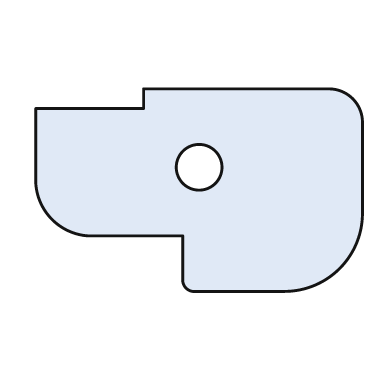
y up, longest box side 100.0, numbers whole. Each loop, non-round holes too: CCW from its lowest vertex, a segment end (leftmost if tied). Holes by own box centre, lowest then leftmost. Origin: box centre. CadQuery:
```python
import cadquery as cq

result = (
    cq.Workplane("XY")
    .moveTo(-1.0, -31.0)
    .lineTo(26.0, -31.0)
    .threePointArc((43.0, -24.0), (50.0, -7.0))
    .lineTo(50.0, 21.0)
    .threePointArc((47.0, 28.0), (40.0, 31.0))
    .lineTo(-17.0, 31.0)
    .lineTo(-17.0, 25.0)
    .lineTo(-50.0, 25.0)
    .lineTo(-50.0, 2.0)
    .threePointArc((-45.0, -9.0), (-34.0, -14.0))
    .lineTo(-5.0, -14.0)
    .lineTo(-5.0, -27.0)
    .threePointArc((-4.0, -30.0), (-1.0, -31.0))
    .close()
    .moveTo(0.0, 7.0)
    .circle(7.0)
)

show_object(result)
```